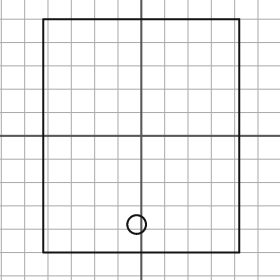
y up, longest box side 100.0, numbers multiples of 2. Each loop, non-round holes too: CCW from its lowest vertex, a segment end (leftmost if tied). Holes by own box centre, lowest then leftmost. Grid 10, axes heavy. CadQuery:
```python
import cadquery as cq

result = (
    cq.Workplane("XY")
    .moveTo(-42.0, -50.0)
    .lineTo(42.0, -50.0)
    .lineTo(42.0, 50.0)
    .lineTo(-42.0, 50.0)
    .close()
    .moveTo(-2.0, -38.0)
    .circle(4.0)
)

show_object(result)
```